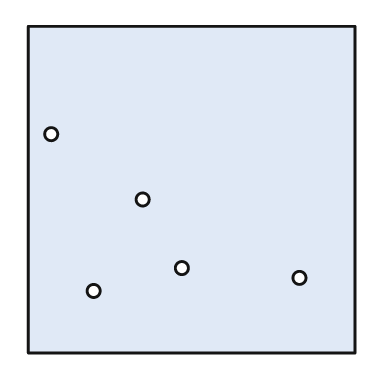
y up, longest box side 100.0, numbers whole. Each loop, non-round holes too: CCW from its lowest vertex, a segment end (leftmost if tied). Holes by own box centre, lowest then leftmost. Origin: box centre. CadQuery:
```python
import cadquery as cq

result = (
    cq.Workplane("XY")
    .moveTo(-50.0, -50.0)
    .lineTo(50.0, -50.0)
    .lineTo(50.0, 50.0)
    .lineTo(-50.0, 50.0)
    .close()
    .moveTo(-30.0, -31.0)
    .circle(2.0)
    .moveTo(33.0, -27.0)
    .circle(2.0)
    .moveTo(-3.0, -24.0)
    .circle(2.0)
    .moveTo(-15.0, -3.0)
    .circle(2.0)
    .moveTo(-43.0, 17.0)
    .circle(2.0)
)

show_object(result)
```